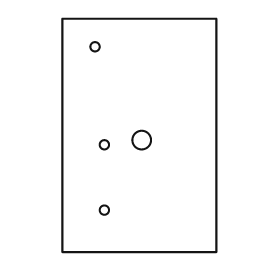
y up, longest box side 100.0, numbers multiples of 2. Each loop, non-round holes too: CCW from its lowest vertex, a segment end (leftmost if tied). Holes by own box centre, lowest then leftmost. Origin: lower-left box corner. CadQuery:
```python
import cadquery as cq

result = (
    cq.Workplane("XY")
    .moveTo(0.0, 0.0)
    .lineTo(66.0, 0.0)
    .lineTo(66.0, 100.0)
    .lineTo(0.0, 100.0)
    .close()
    .moveTo(18.0, 18.0)
    .circle(2.0)
    .moveTo(18.0, 46.0)
    .circle(2.0)
    .moveTo(34.0, 48.0)
    .circle(4.0)
    .moveTo(14.0, 88.0)
    .circle(2.0)
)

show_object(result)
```